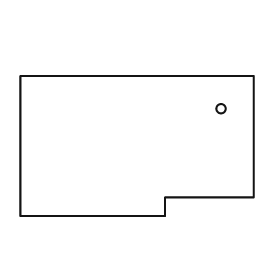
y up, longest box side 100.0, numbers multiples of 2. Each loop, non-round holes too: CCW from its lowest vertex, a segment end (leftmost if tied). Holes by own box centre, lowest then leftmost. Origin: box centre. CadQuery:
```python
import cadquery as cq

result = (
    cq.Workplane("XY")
    .moveTo(-50.0, -30.0)
    .lineTo(12.0, -30.0)
    .lineTo(12.0, -22.0)
    .lineTo(50.0, -22.0)
    .lineTo(50.0, 30.0)
    .lineTo(-50.0, 30.0)
    .close()
    .moveTo(36.0, 16.0)
    .circle(2.0)
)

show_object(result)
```